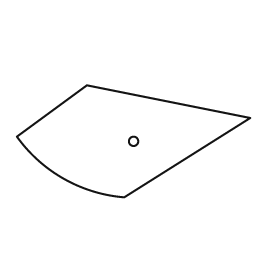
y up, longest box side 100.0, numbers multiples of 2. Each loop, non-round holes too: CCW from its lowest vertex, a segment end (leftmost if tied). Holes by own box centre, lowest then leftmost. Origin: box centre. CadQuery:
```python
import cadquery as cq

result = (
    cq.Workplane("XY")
    .moveTo(-4.0, -24.0)
    .lineTo(50.0, 10.0)
    .lineTo(-20.0, 24.0)
    .lineTo(-50.0, 2.0)
    .threePointArc((-30.0, -16.0), (-4.0, -24.0))
    .close()
    .moveTo(0.0, 0.0)
    .circle(2.0)
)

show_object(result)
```